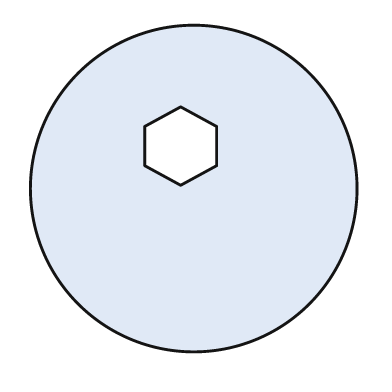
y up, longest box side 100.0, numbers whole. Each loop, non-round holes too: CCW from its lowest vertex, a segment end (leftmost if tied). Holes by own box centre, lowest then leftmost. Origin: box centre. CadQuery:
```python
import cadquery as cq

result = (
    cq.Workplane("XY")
    .moveTo(0.0, 0.0)
    .circle(50.0)
    .moveTo(-4.0, 1.0)
    .lineTo(7.0, 7.0)
    .lineTo(7.0, 19.0)
    .lineTo(-4.0, 25.0)
    .lineTo(-15.0, 19.0)
    .lineTo(-15.0, 7.0)
    .close()
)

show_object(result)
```